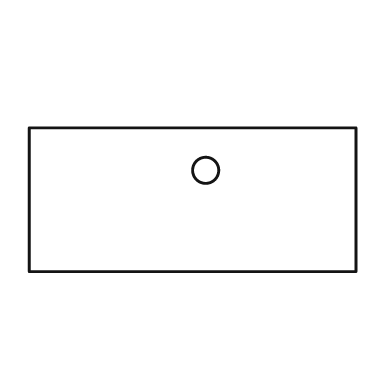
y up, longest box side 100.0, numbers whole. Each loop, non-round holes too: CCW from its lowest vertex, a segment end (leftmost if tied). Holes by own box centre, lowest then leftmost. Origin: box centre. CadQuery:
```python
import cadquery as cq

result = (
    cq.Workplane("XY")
    .moveTo(-50.0, -22.0)
    .lineTo(50.0, -22.0)
    .lineTo(50.0, 22.0)
    .lineTo(-50.0, 22.0)
    .close()
    .moveTo(4.0, 9.0)
    .circle(4.0)
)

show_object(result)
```